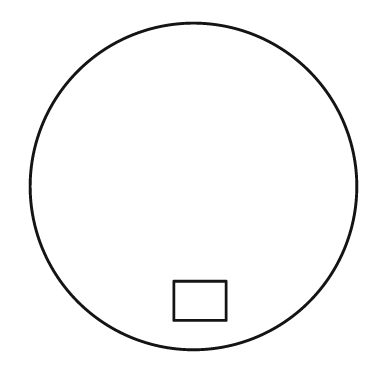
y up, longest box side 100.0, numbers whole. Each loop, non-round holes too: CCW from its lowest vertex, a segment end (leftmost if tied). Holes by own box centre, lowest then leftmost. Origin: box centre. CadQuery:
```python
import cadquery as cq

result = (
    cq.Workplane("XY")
    .moveTo(0.0, 0.0)
    .circle(50.0)
    .moveTo(-6.0, -41.0)
    .lineTo(10.0, -41.0)
    .lineTo(10.0, -29.0)
    .lineTo(-6.0, -29.0)
    .close()
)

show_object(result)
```